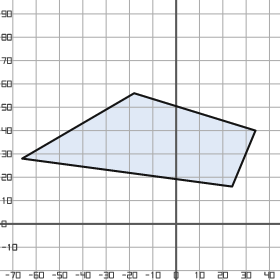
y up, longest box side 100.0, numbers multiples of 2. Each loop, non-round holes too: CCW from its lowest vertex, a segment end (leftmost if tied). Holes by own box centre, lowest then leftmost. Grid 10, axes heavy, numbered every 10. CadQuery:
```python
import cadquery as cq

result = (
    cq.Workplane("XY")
    .moveTo(24.0, 16.0)
    .lineTo(34.0, 40.0)
    .lineTo(-18.0, 56.0)
    .lineTo(-66.0, 28.0)
    .close()
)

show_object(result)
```